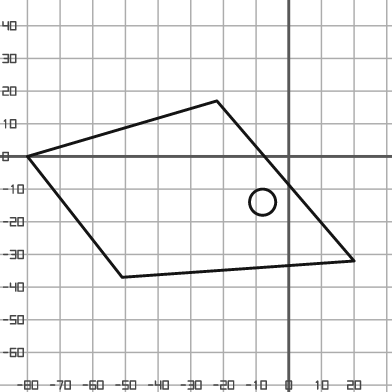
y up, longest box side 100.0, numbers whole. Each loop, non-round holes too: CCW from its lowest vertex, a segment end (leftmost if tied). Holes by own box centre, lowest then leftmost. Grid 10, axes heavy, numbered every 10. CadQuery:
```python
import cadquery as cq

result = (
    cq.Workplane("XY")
    .moveTo(-51.0, -37.0)
    .lineTo(20.0, -32.0)
    .lineTo(-22.0, 17.0)
    .lineTo(-80.0, 0.0)
    .close()
    .moveTo(-8.0, -14.0)
    .circle(4.0)
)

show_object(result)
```